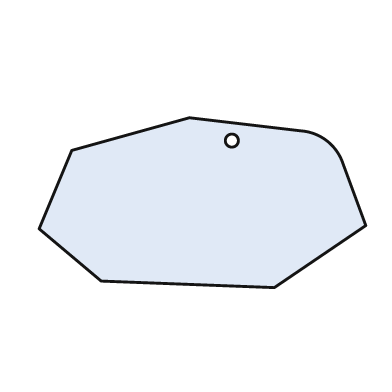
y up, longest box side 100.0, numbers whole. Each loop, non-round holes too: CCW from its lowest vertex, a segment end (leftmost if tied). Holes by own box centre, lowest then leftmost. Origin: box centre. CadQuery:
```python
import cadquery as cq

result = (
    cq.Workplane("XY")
    .moveTo(22.0, -26.0)
    .lineTo(50.0, -7.0)
    .lineTo(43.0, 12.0)
    .threePointArc((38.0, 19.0), (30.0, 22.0))
    .lineTo(-4.0, 26.0)
    .lineTo(-40.0, 16.0)
    .lineTo(-50.0, -8.0)
    .lineTo(-31.0, -24.0)
    .close()
    .moveTo(9.0, 19.0)
    .circle(2.0)
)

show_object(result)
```